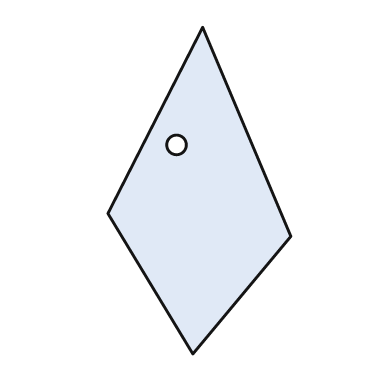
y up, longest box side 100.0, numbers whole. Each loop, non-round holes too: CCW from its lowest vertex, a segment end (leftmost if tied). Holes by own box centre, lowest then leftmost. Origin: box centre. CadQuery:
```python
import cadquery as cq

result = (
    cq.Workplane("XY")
    .moveTo(-2.0, -50.0)
    .lineTo(28.0, -14.0)
    .lineTo(1.0, 50.0)
    .lineTo(-28.0, -7.0)
    .close()
    .moveTo(-7.0, 14.0)
    .circle(3.0)
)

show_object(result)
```